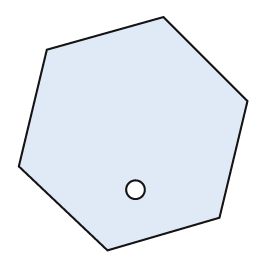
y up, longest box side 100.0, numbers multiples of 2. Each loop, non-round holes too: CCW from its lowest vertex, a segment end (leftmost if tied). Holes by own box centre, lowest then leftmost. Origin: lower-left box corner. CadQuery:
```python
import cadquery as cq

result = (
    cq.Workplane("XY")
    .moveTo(38.0, 0.0)
    .lineTo(86.0, 14.0)
    .lineTo(98.0, 64.0)
    .lineTo(62.0, 100.0)
    .lineTo(12.0, 86.0)
    .lineTo(0.0, 36.0)
    .close()
    .moveTo(50.0, 26.0)
    .circle(4.0)
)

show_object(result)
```